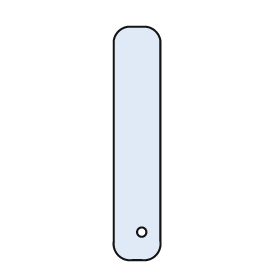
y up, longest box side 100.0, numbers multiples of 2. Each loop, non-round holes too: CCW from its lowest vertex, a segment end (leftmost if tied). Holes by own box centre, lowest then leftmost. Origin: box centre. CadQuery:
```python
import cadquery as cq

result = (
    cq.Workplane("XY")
    .moveTo(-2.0, -50.0)
    .lineTo(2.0, -50.0)
    .threePointArc((8.0, -48.0), (10.0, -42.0))
    .lineTo(10.0, 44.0)
    .threePointArc((8.0, 48.0), (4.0, 50.0))
    .lineTo(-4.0, 50.0)
    .threePointArc((-8.0, 48.0), (-10.0, 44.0))
    .lineTo(-10.0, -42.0)
    .threePointArc((-8.0, -48.0), (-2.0, -50.0))
    .close()
    .moveTo(2.0, -38.0)
    .circle(2.0)
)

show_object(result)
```